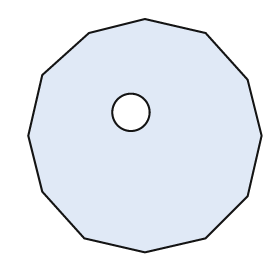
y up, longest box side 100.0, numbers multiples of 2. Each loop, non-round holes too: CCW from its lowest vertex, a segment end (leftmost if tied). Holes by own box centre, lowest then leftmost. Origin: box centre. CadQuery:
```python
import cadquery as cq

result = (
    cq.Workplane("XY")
    .moveTo(0.0, -50.0)
    .lineTo(26.0, -44.0)
    .lineTo(44.0, -26.0)
    .lineTo(50.0, 0.0)
    .lineTo(44.0, 24.0)
    .lineTo(26.0, 44.0)
    .lineTo(0.0, 50.0)
    .lineTo(-24.0, 44.0)
    .lineTo(-44.0, 26.0)
    .lineTo(-50.0, 0.0)
    .lineTo(-44.0, -24.0)
    .lineTo(-26.0, -44.0)
    .close()
    .moveTo(-6.0, 10.0)
    .circle(8.0)
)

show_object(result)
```